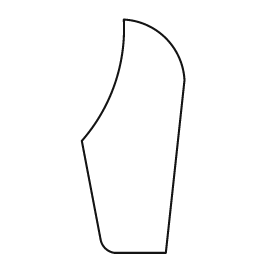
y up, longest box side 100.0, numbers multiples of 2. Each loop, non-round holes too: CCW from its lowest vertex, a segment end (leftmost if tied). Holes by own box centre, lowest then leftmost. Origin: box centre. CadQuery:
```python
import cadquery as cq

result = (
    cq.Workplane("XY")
    .moveTo(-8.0, -50.0)
    .lineTo(14.0, -50.0)
    .lineTo(22.0, 24.0)
    .threePointArc((14.0, 42.0), (-4.0, 50.0))
    .threePointArc((-8.0, 22.0), (-22.0, -2.0))
    .lineTo(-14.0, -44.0)
    .threePointArc((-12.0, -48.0), (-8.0, -50.0))
    .close()
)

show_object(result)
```